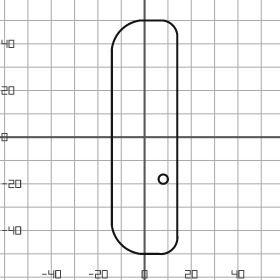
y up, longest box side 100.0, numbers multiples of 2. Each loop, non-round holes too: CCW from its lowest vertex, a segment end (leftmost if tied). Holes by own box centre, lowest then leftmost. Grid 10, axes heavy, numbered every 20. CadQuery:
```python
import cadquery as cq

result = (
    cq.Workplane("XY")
    .moveTo(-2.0, -50.0)
    .lineTo(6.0, -50.0)
    .threePointArc((12.0, -48.0), (14.0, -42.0))
    .lineTo(14.0, 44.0)
    .threePointArc((12.0, 48.0), (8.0, 50.0))
    .lineTo(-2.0, 50.0)
    .threePointArc((-10.0, 46.0), (-14.0, 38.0))
    .lineTo(-14.0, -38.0)
    .threePointArc((-10.0, -46.0), (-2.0, -50.0))
    .close()
    .moveTo(8.0, -18.0)
    .circle(2.0)
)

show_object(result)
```